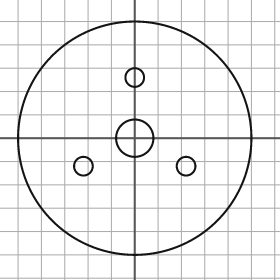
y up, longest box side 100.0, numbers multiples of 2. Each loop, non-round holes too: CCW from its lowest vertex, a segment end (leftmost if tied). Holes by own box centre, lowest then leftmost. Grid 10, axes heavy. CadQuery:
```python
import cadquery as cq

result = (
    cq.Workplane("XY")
    .moveTo(0.0, 0.0)
    .circle(50.0)
    .moveTo(-22.0, -12.0)
    .circle(4.0)
    .moveTo(22.0, -12.0)
    .circle(4.0)
    .moveTo(0.0, 0.0)
    .circle(8.0)
    .moveTo(0.0, 26.0)
    .circle(4.0)
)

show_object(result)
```